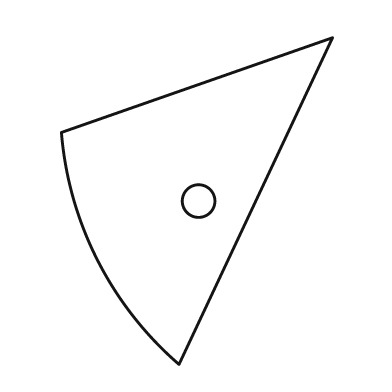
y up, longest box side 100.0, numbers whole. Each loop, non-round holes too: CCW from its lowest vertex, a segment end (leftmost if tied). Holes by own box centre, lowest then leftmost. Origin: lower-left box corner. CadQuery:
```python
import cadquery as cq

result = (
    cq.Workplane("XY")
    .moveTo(36.0, 0.0)
    .lineTo(83.0, 100.0)
    .lineTo(0.0, 71.0)
    .threePointArc((11.0, 32.0), (36.0, 0.0))
    .close()
    .moveTo(42.0, 50.0)
    .circle(5.0)
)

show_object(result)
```